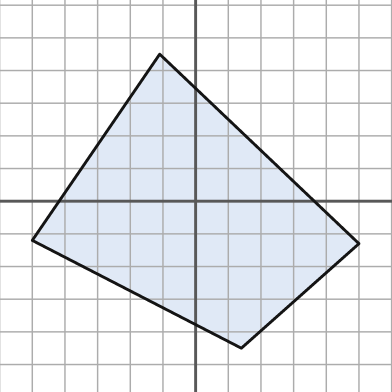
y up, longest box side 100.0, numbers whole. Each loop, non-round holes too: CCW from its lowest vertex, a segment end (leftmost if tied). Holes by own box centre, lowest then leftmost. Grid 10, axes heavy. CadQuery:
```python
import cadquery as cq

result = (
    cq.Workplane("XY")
    .moveTo(14.0, -45.0)
    .lineTo(50.0, -13.0)
    .lineTo(-11.0, 45.0)
    .lineTo(-50.0, -12.0)
    .close()
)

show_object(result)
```